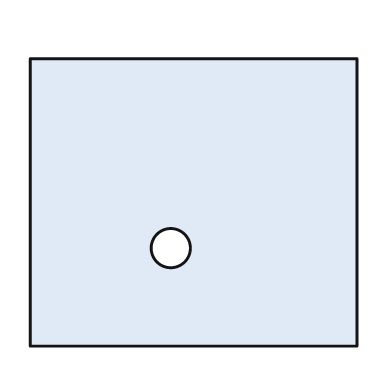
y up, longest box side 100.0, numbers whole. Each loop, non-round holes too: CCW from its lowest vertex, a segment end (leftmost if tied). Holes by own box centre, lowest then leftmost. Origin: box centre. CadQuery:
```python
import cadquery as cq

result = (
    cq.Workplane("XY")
    .moveTo(-50.0, -44.0)
    .lineTo(50.0, -44.0)
    .lineTo(50.0, 44.0)
    .lineTo(-50.0, 44.0)
    .close()
    .moveTo(-7.0, -14.0)
    .circle(6.0)
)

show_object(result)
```